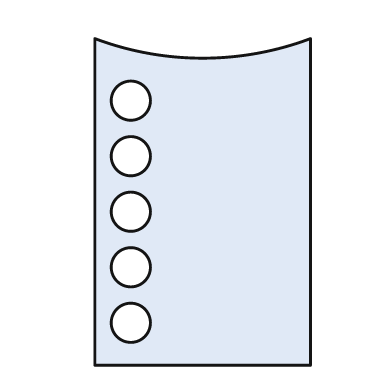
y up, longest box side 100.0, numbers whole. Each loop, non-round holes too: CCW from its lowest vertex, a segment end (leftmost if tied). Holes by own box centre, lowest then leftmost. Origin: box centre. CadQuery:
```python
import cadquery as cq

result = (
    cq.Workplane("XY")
    .moveTo(-33.0, -50.0)
    .lineTo(33.0, -50.0)
    .lineTo(33.0, 50.0)
    .threePointArc((0.0, 44.0), (-33.0, 50.0))
    .close()
    .moveTo(-22.0, -37.0)
    .circle(6.0)
    .moveTo(-22.0, -20.0)
    .circle(6.0)
    .moveTo(-22.0, -3.0)
    .circle(6.0)
    .moveTo(-22.0, 14.0)
    .circle(6.0)
    .moveTo(-22.0, 31.0)
    .circle(6.0)
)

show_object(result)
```